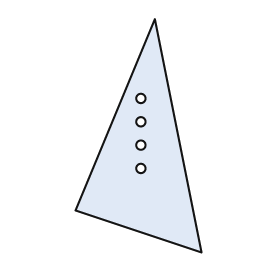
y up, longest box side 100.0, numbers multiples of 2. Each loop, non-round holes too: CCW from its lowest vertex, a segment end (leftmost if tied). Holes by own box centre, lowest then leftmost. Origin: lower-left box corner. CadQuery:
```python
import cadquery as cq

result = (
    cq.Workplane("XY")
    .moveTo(54.0, 0.0)
    .lineTo(34.0, 100.0)
    .lineTo(0.0, 18.0)
    .close()
    .moveTo(28.0, 36.0)
    .circle(2.0)
    .moveTo(28.0, 46.0)
    .circle(2.0)
    .moveTo(28.0, 56.0)
    .circle(2.0)
    .moveTo(28.0, 66.0)
    .circle(2.0)
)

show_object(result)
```